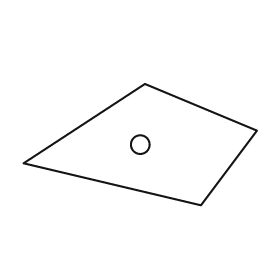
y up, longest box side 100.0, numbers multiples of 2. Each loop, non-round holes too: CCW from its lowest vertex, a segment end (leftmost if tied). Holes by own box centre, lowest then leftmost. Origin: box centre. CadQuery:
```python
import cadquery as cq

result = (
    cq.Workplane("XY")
    .moveTo(26.0, -26.0)
    .lineTo(50.0, 6.0)
    .lineTo(2.0, 26.0)
    .lineTo(-50.0, -8.0)
    .close()
    .moveTo(0.0, 0.0)
    .circle(4.0)
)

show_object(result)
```